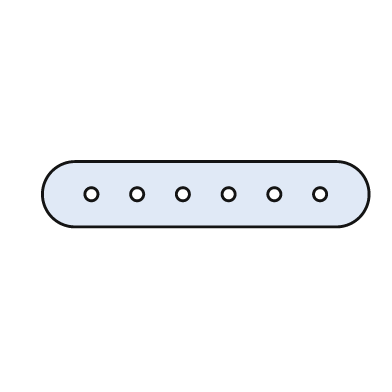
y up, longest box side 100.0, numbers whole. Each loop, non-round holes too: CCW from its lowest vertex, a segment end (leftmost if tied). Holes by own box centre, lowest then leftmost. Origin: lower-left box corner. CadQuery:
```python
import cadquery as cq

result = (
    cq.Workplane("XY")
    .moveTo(10.0, 0.0)
    .lineTo(90.0, 0.0)
    .threePointArc((100.0, 10.0), (90.0, 20.0))
    .lineTo(10.0, 20.0)
    .threePointArc((0.0, 10.0), (10.0, 0.0))
    .close()
    .moveTo(15.0, 10.0)
    .circle(2.0)
    .moveTo(29.0, 10.0)
    .circle(2.0)
    .moveTo(43.0, 10.0)
    .circle(2.0)
    .moveTo(57.0, 10.0)
    .circle(2.0)
    .moveTo(71.0, 10.0)
    .circle(2.0)
    .moveTo(85.0, 10.0)
    .circle(2.0)
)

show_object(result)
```